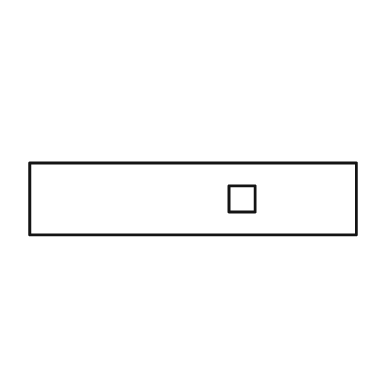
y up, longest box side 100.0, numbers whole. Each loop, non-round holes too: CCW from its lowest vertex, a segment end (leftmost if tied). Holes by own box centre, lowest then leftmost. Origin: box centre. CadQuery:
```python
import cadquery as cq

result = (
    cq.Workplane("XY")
    .moveTo(-50.0, -11.0)
    .lineTo(50.0, -11.0)
    .lineTo(50.0, 11.0)
    .lineTo(-50.0, 11.0)
    .close()
    .moveTo(11.0, -4.0)
    .lineTo(19.0, -4.0)
    .lineTo(19.0, 4.0)
    .lineTo(11.0, 4.0)
    .close()
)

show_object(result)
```